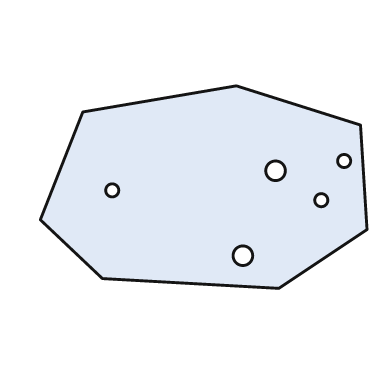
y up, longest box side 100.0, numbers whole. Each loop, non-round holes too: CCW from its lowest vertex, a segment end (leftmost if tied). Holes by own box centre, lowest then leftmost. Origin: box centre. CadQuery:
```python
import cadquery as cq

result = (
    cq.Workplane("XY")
    .moveTo(23.0, -31.0)
    .lineTo(50.0, -13.0)
    .lineTo(48.0, 19.0)
    .lineTo(10.0, 31.0)
    .lineTo(-37.0, 23.0)
    .lineTo(-50.0, -10.0)
    .lineTo(-31.0, -28.0)
    .close()
    .moveTo(12.0, -21.0)
    .circle(3.0)
    .moveTo(36.0, -4.0)
    .circle(2.0)
    .moveTo(-28.0, -1.0)
    .circle(2.0)
    .moveTo(22.0, 5.0)
    .circle(3.0)
    .moveTo(43.0, 8.0)
    .circle(2.0)
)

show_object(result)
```